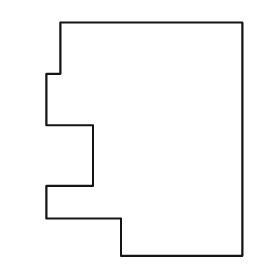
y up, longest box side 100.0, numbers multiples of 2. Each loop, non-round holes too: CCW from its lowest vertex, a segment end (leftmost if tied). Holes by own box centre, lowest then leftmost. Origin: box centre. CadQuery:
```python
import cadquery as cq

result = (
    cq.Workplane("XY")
    .moveTo(-10.0, -50.0)
    .lineTo(42.0, -50.0)
    .lineTo(42.0, 50.0)
    .lineTo(-36.0, 50.0)
    .lineTo(-36.0, 28.0)
    .lineTo(-42.0, 28.0)
    .lineTo(-42.0, 6.0)
    .lineTo(-22.0, 6.0)
    .lineTo(-22.0, -20.0)
    .lineTo(-42.0, -20.0)
    .lineTo(-42.0, -34.0)
    .lineTo(-10.0, -34.0)
    .close()
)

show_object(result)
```